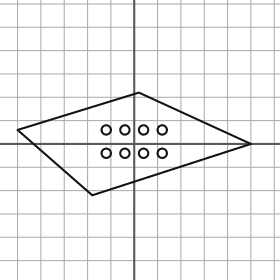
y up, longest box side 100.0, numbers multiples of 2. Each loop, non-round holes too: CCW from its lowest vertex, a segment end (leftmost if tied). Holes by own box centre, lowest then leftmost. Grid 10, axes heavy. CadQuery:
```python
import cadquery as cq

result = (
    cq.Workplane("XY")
    .moveTo(-18.0, -22.0)
    .lineTo(50.0, 0.0)
    .lineTo(2.0, 22.0)
    .lineTo(-50.0, 6.0)
    .close()
    .moveTo(-12.0, -4.0)
    .circle(2.0)
    .moveTo(-4.0, -4.0)
    .circle(2.0)
    .moveTo(4.0, -4.0)
    .circle(2.0)
    .moveTo(12.0, -4.0)
    .circle(2.0)
    .moveTo(-12.0, 6.0)
    .circle(2.0)
    .moveTo(-4.0, 6.0)
    .circle(2.0)
    .moveTo(4.0, 6.0)
    .circle(2.0)
    .moveTo(12.0, 6.0)
    .circle(2.0)
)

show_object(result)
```